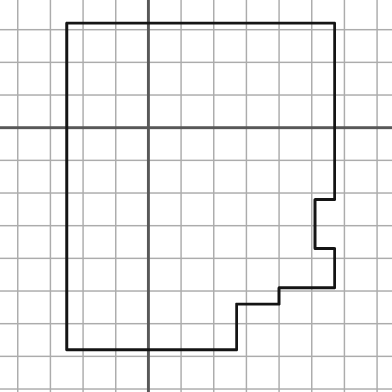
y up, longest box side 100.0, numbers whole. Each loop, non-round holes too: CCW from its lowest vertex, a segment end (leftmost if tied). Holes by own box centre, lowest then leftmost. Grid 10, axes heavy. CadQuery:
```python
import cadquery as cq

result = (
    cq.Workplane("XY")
    .moveTo(-25.0, -68.0)
    .lineTo(27.0, -68.0)
    .lineTo(27.0, -54.0)
    .lineTo(40.0, -54.0)
    .lineTo(40.0, -49.0)
    .lineTo(57.0, -49.0)
    .lineTo(57.0, -37.0)
    .lineTo(51.0, -37.0)
    .lineTo(51.0, -22.0)
    .lineTo(57.0, -22.0)
    .lineTo(57.0, 32.0)
    .lineTo(-25.0, 32.0)
    .close()
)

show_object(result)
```